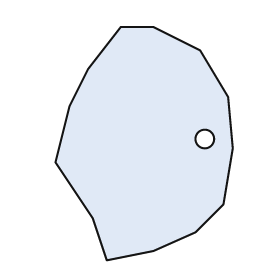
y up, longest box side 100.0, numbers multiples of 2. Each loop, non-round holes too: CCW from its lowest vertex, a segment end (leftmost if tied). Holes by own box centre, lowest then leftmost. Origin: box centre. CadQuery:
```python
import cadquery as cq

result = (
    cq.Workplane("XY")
    .moveTo(-16.0, -50.0)
    .lineTo(4.0, -46.0)
    .lineTo(22.0, -38.0)
    .lineTo(34.0, -26.0)
    .lineTo(38.0, -2.0)
    .lineTo(36.0, 20.0)
    .lineTo(24.0, 40.0)
    .lineTo(4.0, 50.0)
    .lineTo(-10.0, 50.0)
    .lineTo(-24.0, 32.0)
    .lineTo(-32.0, 16.0)
    .lineTo(-38.0, -8.0)
    .lineTo(-22.0, -32.0)
    .close()
    .moveTo(26.0, 2.0)
    .circle(4.0)
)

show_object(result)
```